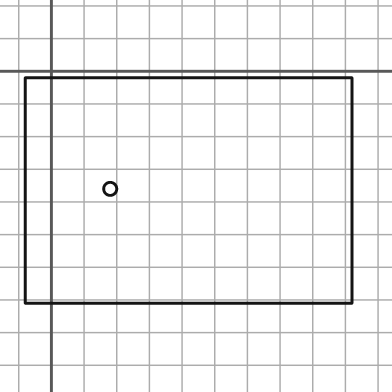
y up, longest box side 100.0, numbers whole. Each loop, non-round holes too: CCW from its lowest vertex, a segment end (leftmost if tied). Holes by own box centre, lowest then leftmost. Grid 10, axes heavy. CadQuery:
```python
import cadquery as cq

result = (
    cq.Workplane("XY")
    .moveTo(-8.0, -71.0)
    .lineTo(92.0, -71.0)
    .lineTo(92.0, -2.0)
    .lineTo(-8.0, -2.0)
    .close()
    .moveTo(18.0, -36.0)
    .circle(2.0)
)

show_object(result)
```